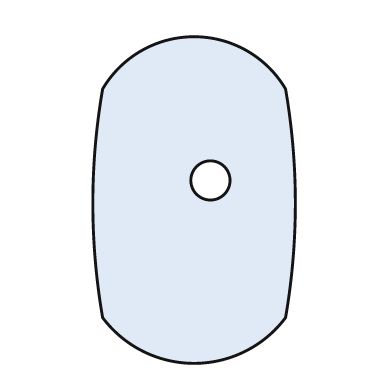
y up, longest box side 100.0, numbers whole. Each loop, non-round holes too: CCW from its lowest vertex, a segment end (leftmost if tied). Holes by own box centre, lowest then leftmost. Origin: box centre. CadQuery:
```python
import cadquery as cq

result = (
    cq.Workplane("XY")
    .moveTo(-28.0, -36.0)
    .threePointArc((0.0, -50.0), (28.0, -36.0))
    .threePointArc((31.0, -1.0), (28.0, 34.0))
    .threePointArc((0.0, 50.0), (-28.0, 34.0))
    .threePointArc((-31.0, -1.0), (-28.0, -36.0))
    .close()
    .moveTo(5.0, 6.0)
    .circle(6.0)
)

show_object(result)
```